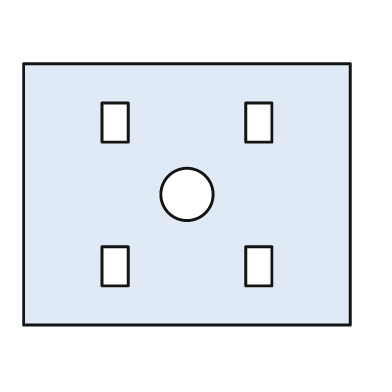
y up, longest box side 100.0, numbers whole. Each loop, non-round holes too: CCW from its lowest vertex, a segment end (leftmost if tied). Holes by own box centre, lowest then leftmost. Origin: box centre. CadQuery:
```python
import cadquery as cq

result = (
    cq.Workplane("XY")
    .moveTo(-50.0, -40.0)
    .lineTo(50.0, -40.0)
    .lineTo(50.0, 40.0)
    .lineTo(-50.0, 40.0)
    .close()
    .moveTo(-26.0, -28.0)
    .lineTo(-18.0, -28.0)
    .lineTo(-18.0, -16.0)
    .lineTo(-26.0, -16.0)
    .close()
    .moveTo(18.0, -28.0)
    .lineTo(26.0, -28.0)
    .lineTo(26.0, -16.0)
    .lineTo(18.0, -16.0)
    .close()
    .moveTo(0.0, 0.0)
    .circle(8.0)
    .moveTo(-26.0, 16.0)
    .lineTo(-18.0, 16.0)
    .lineTo(-18.0, 28.0)
    .lineTo(-26.0, 28.0)
    .close()
    .moveTo(18.0, 16.0)
    .lineTo(26.0, 16.0)
    .lineTo(26.0, 28.0)
    .lineTo(18.0, 28.0)
    .close()
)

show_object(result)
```